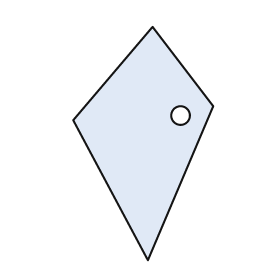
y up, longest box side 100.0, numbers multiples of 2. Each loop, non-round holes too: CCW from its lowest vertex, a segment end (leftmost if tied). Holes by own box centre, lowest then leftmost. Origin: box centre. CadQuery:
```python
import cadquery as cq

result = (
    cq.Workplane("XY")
    .moveTo(2.0, -50.0)
    .lineTo(30.0, 16.0)
    .lineTo(4.0, 50.0)
    .lineTo(-30.0, 10.0)
    .close()
    .moveTo(16.0, 12.0)
    .circle(4.0)
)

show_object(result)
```